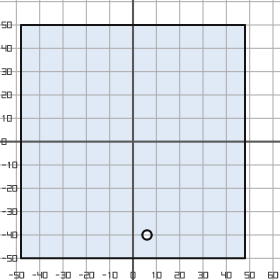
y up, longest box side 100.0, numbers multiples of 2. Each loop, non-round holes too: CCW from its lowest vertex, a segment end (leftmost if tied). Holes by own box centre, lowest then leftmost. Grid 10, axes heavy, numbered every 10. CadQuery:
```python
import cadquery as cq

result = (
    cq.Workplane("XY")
    .moveTo(-48.0, -50.0)
    .lineTo(48.0, -50.0)
    .lineTo(48.0, 50.0)
    .lineTo(-48.0, 50.0)
    .close()
    .moveTo(6.0, -40.0)
    .circle(2.0)
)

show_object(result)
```